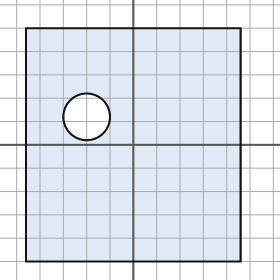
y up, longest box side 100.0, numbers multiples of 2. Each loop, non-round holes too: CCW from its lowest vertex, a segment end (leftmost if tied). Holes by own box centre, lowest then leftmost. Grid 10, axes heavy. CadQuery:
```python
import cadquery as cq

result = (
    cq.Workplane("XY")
    .moveTo(-46.0, -50.0)
    .lineTo(46.0, -50.0)
    .lineTo(46.0, 50.0)
    .lineTo(-46.0, 50.0)
    .close()
    .moveTo(-20.0, 12.0)
    .circle(10.0)
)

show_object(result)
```